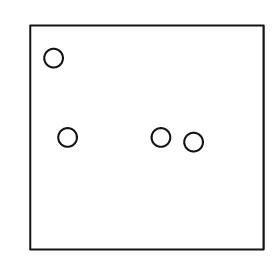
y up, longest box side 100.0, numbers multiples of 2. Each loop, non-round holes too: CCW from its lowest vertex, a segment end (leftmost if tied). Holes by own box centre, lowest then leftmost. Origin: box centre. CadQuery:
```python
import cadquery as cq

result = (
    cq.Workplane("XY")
    .moveTo(-50.0, -48.0)
    .lineTo(50.0, -48.0)
    .lineTo(50.0, 48.0)
    .lineTo(-50.0, 48.0)
    .close()
    .moveTo(20.0, -2.0)
    .circle(4.0)
    .moveTo(-34.0, 0.0)
    .circle(4.0)
    .moveTo(6.0, 0.0)
    .circle(4.0)
    .moveTo(-40.0, 34.0)
    .circle(4.0)
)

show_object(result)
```